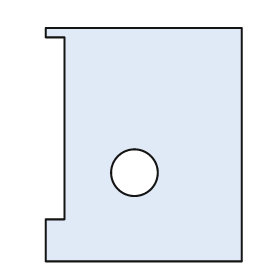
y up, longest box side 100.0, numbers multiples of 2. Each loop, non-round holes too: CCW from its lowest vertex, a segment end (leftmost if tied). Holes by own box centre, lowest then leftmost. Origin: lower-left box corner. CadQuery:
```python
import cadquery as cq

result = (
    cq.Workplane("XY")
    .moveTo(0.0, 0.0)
    .lineTo(84.0, 0.0)
    .lineTo(84.0, 100.0)
    .lineTo(0.0, 100.0)
    .lineTo(0.0, 96.0)
    .lineTo(8.0, 96.0)
    .lineTo(8.0, 18.0)
    .lineTo(0.0, 18.0)
    .close()
    .moveTo(38.0, 38.0)
    .circle(10.0)
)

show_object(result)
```